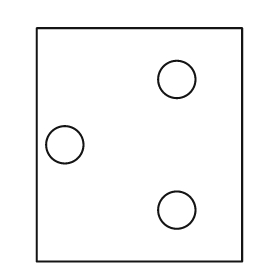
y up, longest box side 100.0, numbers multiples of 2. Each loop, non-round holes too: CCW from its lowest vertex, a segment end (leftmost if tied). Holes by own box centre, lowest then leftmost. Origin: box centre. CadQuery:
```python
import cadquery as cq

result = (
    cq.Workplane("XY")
    .moveTo(-44.0, -50.0)
    .lineTo(44.0, -50.0)
    .lineTo(44.0, 50.0)
    .lineTo(-44.0, 50.0)
    .close()
    .moveTo(16.0, -28.0)
    .circle(8.0)
    .moveTo(-32.0, 0.0)
    .circle(8.0)
    .moveTo(16.0, 28.0)
    .circle(8.0)
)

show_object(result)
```